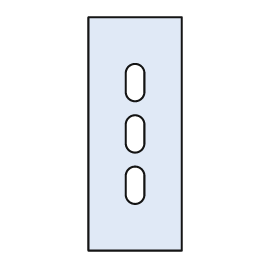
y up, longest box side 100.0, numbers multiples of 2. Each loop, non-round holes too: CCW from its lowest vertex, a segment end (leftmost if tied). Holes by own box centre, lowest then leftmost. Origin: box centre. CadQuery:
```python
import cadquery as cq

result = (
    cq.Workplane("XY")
    .moveTo(-20.0, -50.0)
    .lineTo(20.0, -50.0)
    .lineTo(20.0, 50.0)
    .lineTo(-20.0, 50.0)
    .close()
    .moveTo(-4.0, -26.0)
    .threePointArc((0.0, -30.0), (4.0, -26.0))
    .lineTo(4.0, -18.0)
    .threePointArc((0.0, -14.0), (-4.0, -18.0))
    .close()
    .moveTo(-4.0, -4.0)
    .threePointArc((0.0, -8.0), (4.0, -4.0))
    .lineTo(4.0, 4.0)
    .threePointArc((0.0, 8.0), (-4.0, 4.0))
    .close()
    .moveTo(-4.0, 18.0)
    .threePointArc((0.0, 14.0), (4.0, 18.0))
    .lineTo(4.0, 26.0)
    .threePointArc((0.0, 30.0), (-4.0, 26.0))
    .close()
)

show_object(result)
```